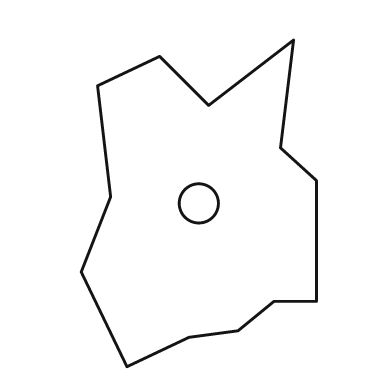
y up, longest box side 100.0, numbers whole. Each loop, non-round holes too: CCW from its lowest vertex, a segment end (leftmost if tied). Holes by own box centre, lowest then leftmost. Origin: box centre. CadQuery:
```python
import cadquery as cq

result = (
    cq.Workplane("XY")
    .moveTo(-22.0, -50.0)
    .lineTo(-3.0, -41.0)
    .lineTo(12.0, -39.0)
    .lineTo(23.0, -30.0)
    .lineTo(36.0, -30.0)
    .lineTo(36.0, 7.0)
    .lineTo(25.0, 17.0)
    .lineTo(29.0, 50.0)
    .lineTo(3.0, 30.0)
    .lineTo(-12.0, 45.0)
    .lineTo(-31.0, 36.0)
    .lineTo(-27.0, 2.0)
    .lineTo(-36.0, -21.0)
    .close()
    .moveTo(0.0, 0.0)
    .circle(6.0)
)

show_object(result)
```